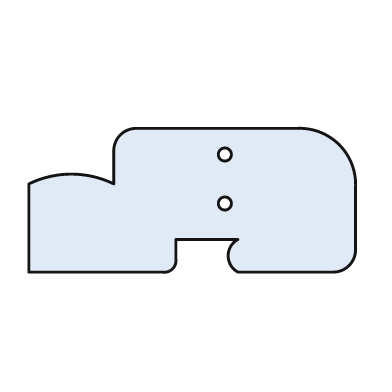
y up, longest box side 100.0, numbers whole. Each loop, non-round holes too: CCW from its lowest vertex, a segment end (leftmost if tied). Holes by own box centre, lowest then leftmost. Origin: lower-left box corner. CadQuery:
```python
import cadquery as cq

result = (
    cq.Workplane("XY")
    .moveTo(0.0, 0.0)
    .lineTo(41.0, 0.0)
    .threePointArc((44.0, 1.0), (45.0, 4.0))
    .lineTo(45.0, 10.0)
    .lineTo(64.0, 10.0)
    .threePointArc((61.0, 5.0), (64.0, 0.0))
    .lineTo(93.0, 0.0)
    .threePointArc((98.0, 2.0), (100.0, 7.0))
    .lineTo(100.0, 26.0)
    .threePointArc((95.0, 39.0), (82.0, 44.0))
    .lineTo(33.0, 44.0)
    .threePointArc((28.0, 42.0), (26.0, 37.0))
    .lineTo(26.0, 27.0)
    .threePointArc((13.0, 30.0), (0.0, 27.0))
    .close()
    .moveTo(60.0, 21.0)
    .circle(2.0)
    .moveTo(60.0, 36.0)
    .circle(2.0)
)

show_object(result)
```